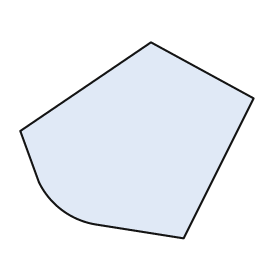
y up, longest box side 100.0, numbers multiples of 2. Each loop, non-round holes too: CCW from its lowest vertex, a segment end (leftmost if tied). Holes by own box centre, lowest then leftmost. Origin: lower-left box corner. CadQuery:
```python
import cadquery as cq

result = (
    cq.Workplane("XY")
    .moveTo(70.0, 0.0)
    .lineTo(100.0, 60.0)
    .lineTo(56.0, 84.0)
    .lineTo(0.0, 46.0)
    .lineTo(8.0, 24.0)
    .threePointArc((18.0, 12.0), (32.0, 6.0))
    .close()
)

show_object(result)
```